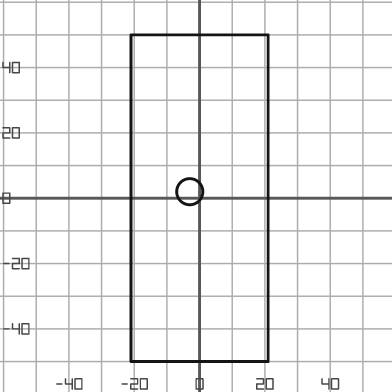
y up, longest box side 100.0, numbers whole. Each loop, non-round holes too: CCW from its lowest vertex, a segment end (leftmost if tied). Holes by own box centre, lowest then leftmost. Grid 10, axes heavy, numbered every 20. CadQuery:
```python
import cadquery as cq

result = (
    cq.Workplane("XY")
    .moveTo(-21.0, -50.0)
    .lineTo(21.0, -50.0)
    .lineTo(21.0, 50.0)
    .lineTo(-21.0, 50.0)
    .close()
    .moveTo(-3.0, 2.0)
    .circle(4.0)
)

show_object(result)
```